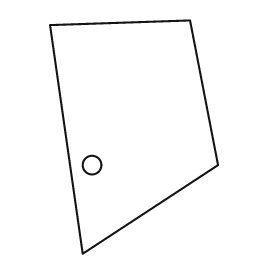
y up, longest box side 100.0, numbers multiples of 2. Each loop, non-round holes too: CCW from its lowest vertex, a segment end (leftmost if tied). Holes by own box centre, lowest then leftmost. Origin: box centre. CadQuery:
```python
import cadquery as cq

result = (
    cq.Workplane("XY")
    .moveTo(-22.0, -50.0)
    .lineTo(36.0, -12.0)
    .lineTo(24.0, 50.0)
    .lineTo(-36.0, 48.0)
    .close()
    .moveTo(-18.0, -12.0)
    .circle(4.0)
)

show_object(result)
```